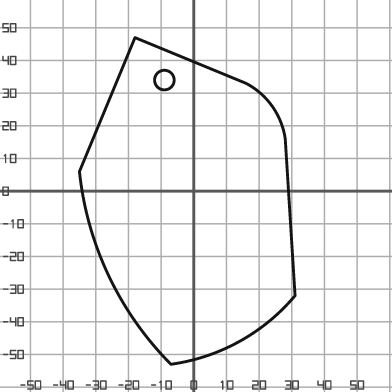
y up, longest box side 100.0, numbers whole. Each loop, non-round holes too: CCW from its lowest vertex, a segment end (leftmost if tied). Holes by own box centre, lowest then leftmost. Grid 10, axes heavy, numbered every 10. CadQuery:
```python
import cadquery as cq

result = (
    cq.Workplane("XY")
    .moveTo(-7.0, -53.0)
    .threePointArc((14.0, -46.0), (31.0, -32.0))
    .lineTo(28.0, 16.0)
    .threePointArc((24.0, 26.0), (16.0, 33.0))
    .lineTo(-18.0, 47.0)
    .lineTo(-35.0, 6.0)
    .threePointArc((-26.0, -26.0), (-7.0, -53.0))
    .close()
    .moveTo(-9.0, 34.0)
    .circle(3.0)
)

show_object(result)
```